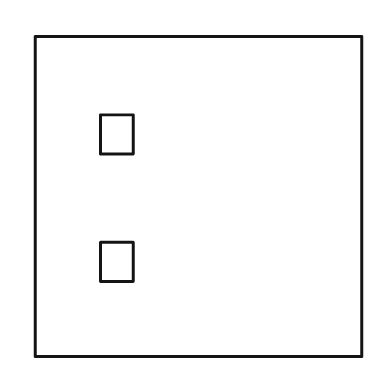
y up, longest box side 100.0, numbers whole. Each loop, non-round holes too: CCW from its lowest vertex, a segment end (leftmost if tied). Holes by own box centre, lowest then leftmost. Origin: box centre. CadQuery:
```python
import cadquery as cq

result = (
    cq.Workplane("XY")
    .moveTo(-50.0, -49.0)
    .lineTo(50.0, -49.0)
    .lineTo(50.0, 49.0)
    .lineTo(-50.0, 49.0)
    .close()
    .moveTo(-30.0, -26.0)
    .lineTo(-20.0, -26.0)
    .lineTo(-20.0, -14.0)
    .lineTo(-30.0, -14.0)
    .close()
    .moveTo(-30.0, 13.0)
    .lineTo(-20.0, 13.0)
    .lineTo(-20.0, 25.0)
    .lineTo(-30.0, 25.0)
    .close()
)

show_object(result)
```